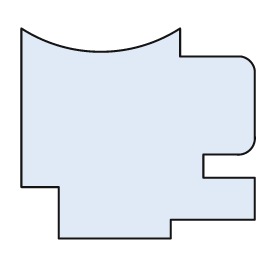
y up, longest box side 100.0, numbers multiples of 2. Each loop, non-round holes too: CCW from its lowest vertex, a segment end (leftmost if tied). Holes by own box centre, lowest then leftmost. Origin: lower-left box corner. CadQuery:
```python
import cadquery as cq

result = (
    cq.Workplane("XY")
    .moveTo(16.0, 0.0)
    .lineTo(64.0, 0.0)
    .lineTo(64.0, 8.0)
    .lineTo(100.0, 8.0)
    .lineTo(100.0, 26.0)
    .lineTo(78.0, 26.0)
    .lineTo(78.0, 36.0)
    .lineTo(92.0, 36.0)
    .threePointArc((98.0, 38.0), (100.0, 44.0))
    .lineTo(100.0, 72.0)
    .threePointArc((98.0, 76.0), (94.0, 78.0))
    .lineTo(68.0, 78.0)
    .lineTo(68.0, 90.0)
    .threePointArc((34.0, 80.0), (0.0, 90.0))
    .lineTo(0.0, 22.0)
    .lineTo(16.0, 22.0)
    .close()
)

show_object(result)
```